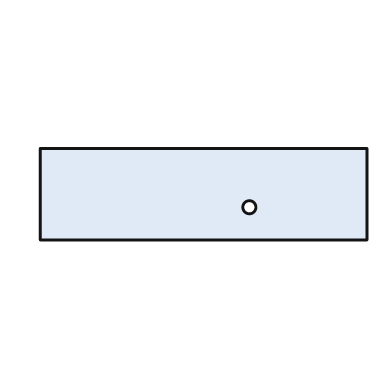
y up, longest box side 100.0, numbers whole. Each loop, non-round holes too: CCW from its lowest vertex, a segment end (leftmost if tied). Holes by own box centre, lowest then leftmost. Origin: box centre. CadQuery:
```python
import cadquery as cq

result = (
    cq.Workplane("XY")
    .moveTo(-50.0, -14.0)
    .lineTo(50.0, -14.0)
    .lineTo(50.0, 14.0)
    .lineTo(-50.0, 14.0)
    .close()
    .moveTo(14.0, -4.0)
    .circle(2.0)
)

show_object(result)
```